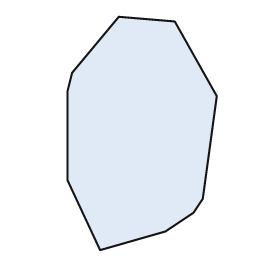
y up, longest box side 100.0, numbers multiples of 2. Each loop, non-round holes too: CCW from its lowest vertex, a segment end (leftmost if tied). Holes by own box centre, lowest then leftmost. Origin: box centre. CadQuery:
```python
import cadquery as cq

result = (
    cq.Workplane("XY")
    .moveTo(-18.0, -50.0)
    .lineTo(10.0, -42.0)
    .lineTo(22.0, -34.0)
    .lineTo(26.0, -28.0)
    .lineTo(32.0, 16.0)
    .lineTo(14.0, 48.0)
    .lineTo(-10.0, 50.0)
    .lineTo(-30.0, 26.0)
    .lineTo(-32.0, 18.0)
    .lineTo(-32.0, -20.0)
    .close()
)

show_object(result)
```